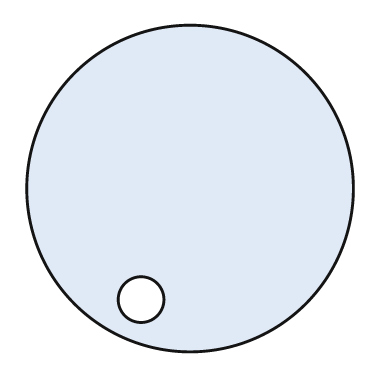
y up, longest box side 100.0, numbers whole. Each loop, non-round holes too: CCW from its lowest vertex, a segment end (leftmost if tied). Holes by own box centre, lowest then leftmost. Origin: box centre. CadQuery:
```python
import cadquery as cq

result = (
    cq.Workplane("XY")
    .moveTo(0.0, 0.0)
    .circle(50.0)
    .moveTo(-15.0, -34.0)
    .circle(7.0)
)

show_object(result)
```